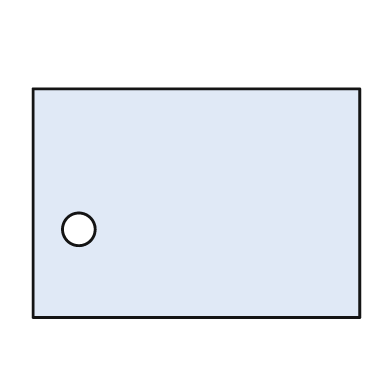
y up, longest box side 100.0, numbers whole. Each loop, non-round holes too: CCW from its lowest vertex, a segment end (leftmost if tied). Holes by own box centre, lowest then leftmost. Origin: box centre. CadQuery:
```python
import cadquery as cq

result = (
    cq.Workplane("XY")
    .moveTo(-50.0, -35.0)
    .lineTo(50.0, -35.0)
    .lineTo(50.0, 35.0)
    .lineTo(-50.0, 35.0)
    .close()
    .moveTo(-36.0, -8.0)
    .circle(5.0)
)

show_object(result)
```